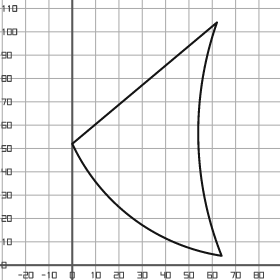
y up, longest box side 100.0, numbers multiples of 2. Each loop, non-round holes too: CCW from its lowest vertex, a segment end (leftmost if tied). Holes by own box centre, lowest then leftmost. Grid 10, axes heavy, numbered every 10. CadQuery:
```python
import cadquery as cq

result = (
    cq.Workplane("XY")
    .moveTo(64.0, 4.0)
    .threePointArc((54.0, 54.0), (62.0, 104.0))
    .lineTo(0.0, 52.0)
    .threePointArc((26.0, 20.0), (64.0, 4.0))
    .close()
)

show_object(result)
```